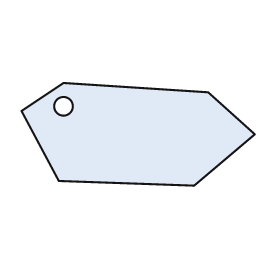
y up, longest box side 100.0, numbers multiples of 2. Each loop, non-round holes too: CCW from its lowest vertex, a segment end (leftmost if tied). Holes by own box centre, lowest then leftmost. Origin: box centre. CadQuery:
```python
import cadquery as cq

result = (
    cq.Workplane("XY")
    .moveTo(24.0, -22.0)
    .lineTo(50.0, 0.0)
    .lineTo(30.0, 18.0)
    .lineTo(-32.0, 22.0)
    .lineTo(-50.0, 10.0)
    .lineTo(-34.0, -20.0)
    .close()
    .moveTo(-32.0, 12.0)
    .circle(4.0)
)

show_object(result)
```